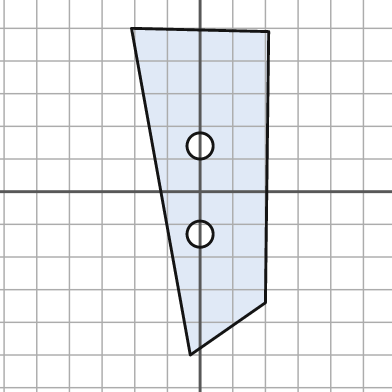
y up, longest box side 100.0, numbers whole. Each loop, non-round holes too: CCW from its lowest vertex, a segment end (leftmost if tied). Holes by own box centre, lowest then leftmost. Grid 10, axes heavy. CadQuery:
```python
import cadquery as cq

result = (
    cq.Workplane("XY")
    .moveTo(-3.0, -50.0)
    .lineTo(20.0, -34.0)
    .lineTo(21.0, 49.0)
    .lineTo(-21.0, 50.0)
    .close()
    .moveTo(0.0, -13.0)
    .circle(4.0)
    .moveTo(0.0, 14.0)
    .circle(4.0)
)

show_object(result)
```